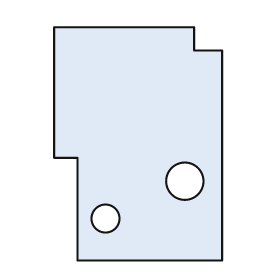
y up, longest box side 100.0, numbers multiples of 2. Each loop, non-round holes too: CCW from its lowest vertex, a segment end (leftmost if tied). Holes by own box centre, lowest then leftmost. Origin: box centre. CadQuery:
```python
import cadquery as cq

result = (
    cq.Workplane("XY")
    .moveTo(-26.0, -50.0)
    .lineTo(36.0, -50.0)
    .lineTo(36.0, 40.0)
    .lineTo(24.0, 40.0)
    .lineTo(24.0, 50.0)
    .lineTo(-36.0, 50.0)
    .lineTo(-36.0, -6.0)
    .lineTo(-26.0, -6.0)
    .close()
    .moveTo(-14.0, -32.0)
    .circle(6.0)
    .moveTo(20.0, -16.0)
    .circle(8.0)
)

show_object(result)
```